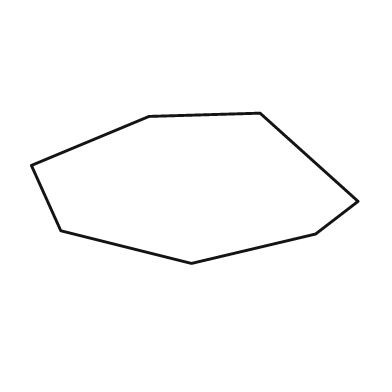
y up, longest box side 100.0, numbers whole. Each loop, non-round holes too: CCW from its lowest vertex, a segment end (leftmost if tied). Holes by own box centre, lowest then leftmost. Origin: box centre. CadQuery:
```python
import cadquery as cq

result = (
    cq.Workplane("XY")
    .moveTo(-1.0, -23.0)
    .lineTo(37.0, -14.0)
    .lineTo(50.0, -4.0)
    .lineTo(20.0, 23.0)
    .lineTo(-14.0, 22.0)
    .lineTo(-50.0, 7.0)
    .lineTo(-41.0, -13.0)
    .close()
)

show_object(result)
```